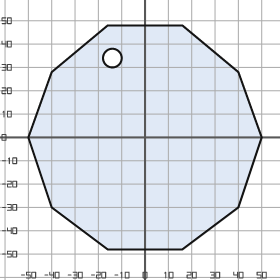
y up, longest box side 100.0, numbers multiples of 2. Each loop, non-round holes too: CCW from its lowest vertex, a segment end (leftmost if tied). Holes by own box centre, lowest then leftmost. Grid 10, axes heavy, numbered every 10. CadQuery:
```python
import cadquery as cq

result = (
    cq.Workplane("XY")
    .moveTo(-16.0, -48.0)
    .lineTo(16.0, -48.0)
    .lineTo(40.0, -30.0)
    .lineTo(50.0, 0.0)
    .lineTo(40.0, 28.0)
    .lineTo(16.0, 48.0)
    .lineTo(-16.0, 48.0)
    .lineTo(-40.0, 28.0)
    .lineTo(-50.0, 0.0)
    .lineTo(-40.0, -30.0)
    .close()
    .moveTo(-14.0, 34.0)
    .circle(4.0)
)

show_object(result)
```